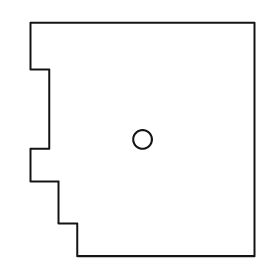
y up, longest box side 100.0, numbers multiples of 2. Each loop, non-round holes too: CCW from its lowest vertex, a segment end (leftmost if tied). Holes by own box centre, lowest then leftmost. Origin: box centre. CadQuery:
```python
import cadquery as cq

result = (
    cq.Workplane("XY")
    .moveTo(-28.0, -50.0)
    .lineTo(48.0, -50.0)
    .lineTo(48.0, 50.0)
    .lineTo(-48.0, 50.0)
    .lineTo(-48.0, 30.0)
    .lineTo(-40.0, 30.0)
    .lineTo(-40.0, -4.0)
    .lineTo(-48.0, -4.0)
    .lineTo(-48.0, -18.0)
    .lineTo(-36.0, -18.0)
    .lineTo(-36.0, -36.0)
    .lineTo(-28.0, -36.0)
    .close()
    .moveTo(0.0, 0.0)
    .circle(4.0)
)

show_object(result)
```